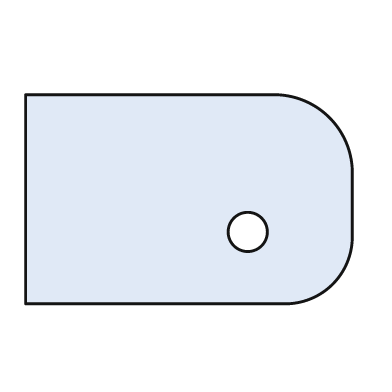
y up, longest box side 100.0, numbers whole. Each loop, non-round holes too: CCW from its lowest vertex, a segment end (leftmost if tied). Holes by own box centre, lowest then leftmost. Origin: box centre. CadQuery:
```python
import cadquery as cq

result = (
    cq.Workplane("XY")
    .moveTo(-50.0, -32.0)
    .lineTo(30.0, -32.0)
    .threePointArc((44.0, -26.0), (50.0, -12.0))
    .lineTo(50.0, 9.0)
    .threePointArc((43.0, 25.0), (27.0, 32.0))
    .lineTo(-50.0, 32.0)
    .close()
    .moveTo(18.0, -10.0)
    .circle(6.0)
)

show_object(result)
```